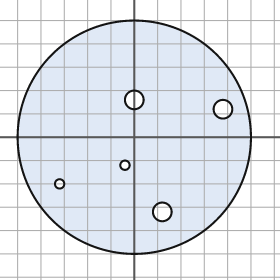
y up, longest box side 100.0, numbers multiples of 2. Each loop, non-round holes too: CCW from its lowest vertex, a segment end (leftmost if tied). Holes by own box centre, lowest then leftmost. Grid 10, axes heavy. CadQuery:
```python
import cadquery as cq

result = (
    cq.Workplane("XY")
    .moveTo(0.0, 0.0)
    .circle(50.0)
    .moveTo(12.0, -32.0)
    .circle(4.0)
    .moveTo(-32.0, -20.0)
    .circle(2.0)
    .moveTo(-4.0, -12.0)
    .circle(2.0)
    .moveTo(38.0, 12.0)
    .circle(4.0)
    .moveTo(0.0, 16.0)
    .circle(4.0)
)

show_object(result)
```